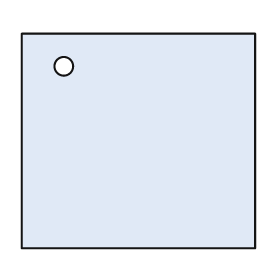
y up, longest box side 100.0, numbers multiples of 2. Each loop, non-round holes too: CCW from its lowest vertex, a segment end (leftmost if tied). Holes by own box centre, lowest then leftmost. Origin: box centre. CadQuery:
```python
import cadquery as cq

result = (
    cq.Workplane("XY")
    .moveTo(-50.0, -46.0)
    .lineTo(50.0, -46.0)
    .lineTo(50.0, 46.0)
    .lineTo(-50.0, 46.0)
    .close()
    .moveTo(-32.0, 32.0)
    .circle(4.0)
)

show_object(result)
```